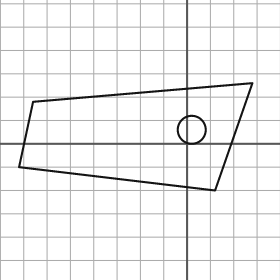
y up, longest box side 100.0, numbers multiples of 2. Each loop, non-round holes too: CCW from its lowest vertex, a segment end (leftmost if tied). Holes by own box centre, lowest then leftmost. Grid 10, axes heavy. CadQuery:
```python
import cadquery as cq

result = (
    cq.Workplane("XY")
    .moveTo(12.0, -20.0)
    .lineTo(28.0, 26.0)
    .lineTo(-66.0, 18.0)
    .lineTo(-72.0, -10.0)
    .close()
    .moveTo(2.0, 6.0)
    .circle(6.0)
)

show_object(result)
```